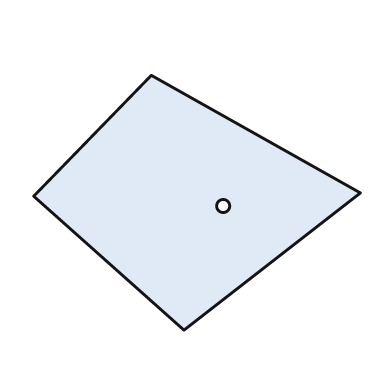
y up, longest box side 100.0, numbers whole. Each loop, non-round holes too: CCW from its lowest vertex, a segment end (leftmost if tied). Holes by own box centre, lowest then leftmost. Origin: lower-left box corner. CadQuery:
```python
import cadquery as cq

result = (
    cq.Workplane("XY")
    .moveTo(46.0, 0.0)
    .lineTo(100.0, 42.0)
    .lineTo(36.0, 78.0)
    .lineTo(0.0, 41.0)
    .close()
    .moveTo(58.0, 38.0)
    .circle(2.0)
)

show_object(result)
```